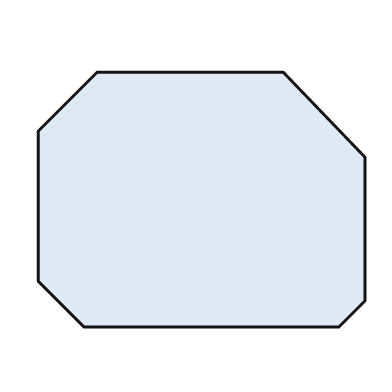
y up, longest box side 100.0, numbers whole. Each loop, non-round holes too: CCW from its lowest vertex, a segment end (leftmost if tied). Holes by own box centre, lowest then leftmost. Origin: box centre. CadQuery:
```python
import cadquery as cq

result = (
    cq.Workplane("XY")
    .moveTo(-36.0, -39.0)
    .lineTo(42.0, -39.0)
    .lineTo(50.0, -31.0)
    .lineTo(50.0, 13.0)
    .lineTo(25.0, 39.0)
    .lineTo(-32.0, 39.0)
    .lineTo(-50.0, 21.0)
    .lineTo(-50.0, -25.0)
    .close()
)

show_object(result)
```